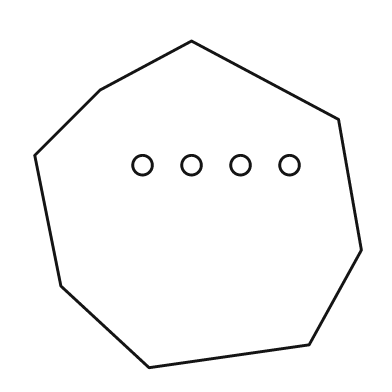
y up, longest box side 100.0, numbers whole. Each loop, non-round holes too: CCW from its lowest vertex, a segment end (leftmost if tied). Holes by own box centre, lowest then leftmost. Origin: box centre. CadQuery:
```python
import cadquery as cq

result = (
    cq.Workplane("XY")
    .moveTo(-15.0, -50.0)
    .lineTo(34.0, -43.0)
    .lineTo(50.0, -14.0)
    .lineTo(43.0, 26.0)
    .lineTo(-2.0, 50.0)
    .lineTo(-30.0, 35.0)
    .lineTo(-50.0, 15.0)
    .lineTo(-42.0, -25.0)
    .close()
    .moveTo(-17.0, 12.0)
    .circle(3.0)
    .moveTo(-2.0, 12.0)
    .circle(3.0)
    .moveTo(13.0, 12.0)
    .circle(3.0)
    .moveTo(28.0, 12.0)
    .circle(3.0)
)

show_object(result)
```